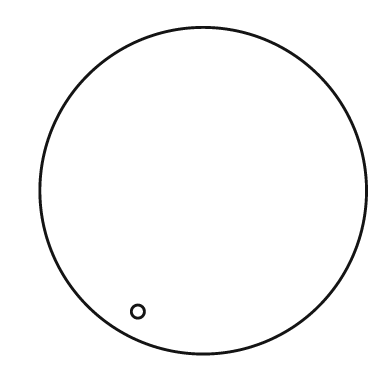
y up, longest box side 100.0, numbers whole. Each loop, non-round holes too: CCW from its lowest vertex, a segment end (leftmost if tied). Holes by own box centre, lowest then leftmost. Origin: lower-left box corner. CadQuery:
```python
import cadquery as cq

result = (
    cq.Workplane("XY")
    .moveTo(50.0, 50.0)
    .circle(50.0)
    .moveTo(30.0, 13.0)
    .circle(2.0)
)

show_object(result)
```